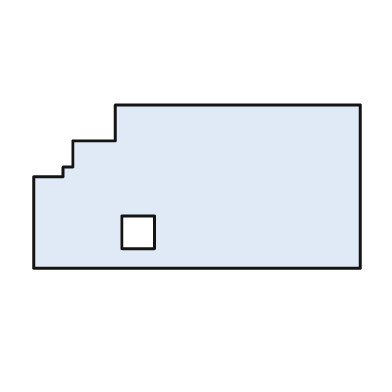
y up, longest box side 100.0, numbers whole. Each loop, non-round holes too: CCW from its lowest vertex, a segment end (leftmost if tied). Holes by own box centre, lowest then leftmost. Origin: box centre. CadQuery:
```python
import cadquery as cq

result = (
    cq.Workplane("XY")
    .moveTo(-50.0, -25.0)
    .lineTo(50.0, -25.0)
    .lineTo(50.0, 25.0)
    .lineTo(-25.0, 25.0)
    .lineTo(-25.0, 14.0)
    .lineTo(-38.0, 14.0)
    .lineTo(-38.0, 6.0)
    .lineTo(-41.0, 6.0)
    .lineTo(-41.0, 3.0)
    .lineTo(-50.0, 3.0)
    .close()
    .moveTo(-23.0, -19.0)
    .lineTo(-13.0, -19.0)
    .lineTo(-13.0, -9.0)
    .lineTo(-23.0, -9.0)
    .close()
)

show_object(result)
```